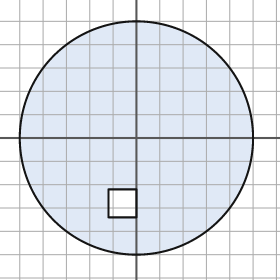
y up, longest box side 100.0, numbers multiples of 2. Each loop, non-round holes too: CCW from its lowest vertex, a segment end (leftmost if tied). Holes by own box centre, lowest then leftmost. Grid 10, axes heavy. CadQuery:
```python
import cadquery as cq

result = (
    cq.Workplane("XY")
    .moveTo(0.0, 0.0)
    .circle(50.0)
    .moveTo(-12.0, -34.0)
    .lineTo(0.0, -34.0)
    .lineTo(0.0, -22.0)
    .lineTo(-12.0, -22.0)
    .close()
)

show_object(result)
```